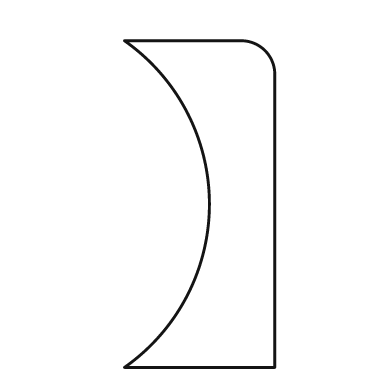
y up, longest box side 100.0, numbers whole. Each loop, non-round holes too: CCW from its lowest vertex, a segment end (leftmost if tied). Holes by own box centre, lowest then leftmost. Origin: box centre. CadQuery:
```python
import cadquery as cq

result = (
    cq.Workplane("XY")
    .moveTo(-23.0, -50.0)
    .lineTo(23.0, -50.0)
    .lineTo(23.0, 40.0)
    .threePointArc((20.0, 47.0), (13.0, 50.0))
    .lineTo(-23.0, 50.0)
    .threePointArc((3.0, 0.0), (-23.0, -50.0))
    .close()
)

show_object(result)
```